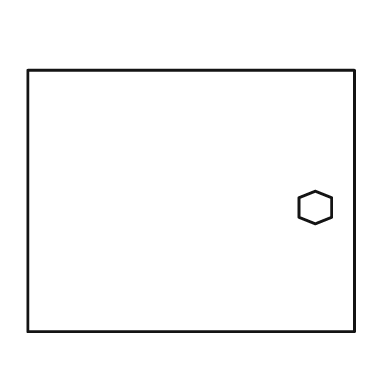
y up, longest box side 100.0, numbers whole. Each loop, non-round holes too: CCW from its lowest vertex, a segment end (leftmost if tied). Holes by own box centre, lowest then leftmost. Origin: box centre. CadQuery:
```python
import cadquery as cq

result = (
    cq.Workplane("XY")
    .moveTo(-50.0, -40.0)
    .lineTo(50.0, -40.0)
    .lineTo(50.0, 40.0)
    .lineTo(-50.0, 40.0)
    .close()
    .moveTo(38.0, -7.0)
    .lineTo(43.0, -5.0)
    .lineTo(43.0, 1.0)
    .lineTo(38.0, 3.0)
    .lineTo(33.0, 1.0)
    .lineTo(33.0, -5.0)
    .close()
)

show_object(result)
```